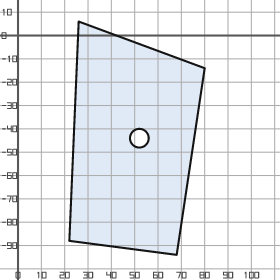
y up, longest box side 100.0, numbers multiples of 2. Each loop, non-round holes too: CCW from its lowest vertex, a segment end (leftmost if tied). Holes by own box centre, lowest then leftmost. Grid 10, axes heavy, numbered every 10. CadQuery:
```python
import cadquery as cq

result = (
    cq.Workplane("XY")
    .moveTo(68.0, -94.0)
    .lineTo(80.0, -14.0)
    .lineTo(26.0, 6.0)
    .lineTo(22.0, -88.0)
    .close()
    .moveTo(52.0, -44.0)
    .circle(4.0)
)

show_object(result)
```